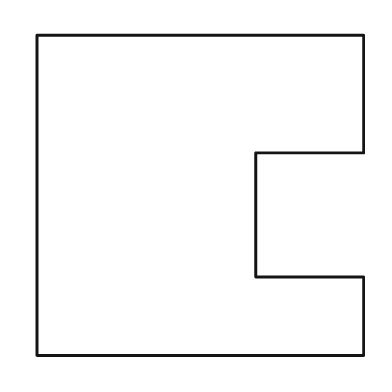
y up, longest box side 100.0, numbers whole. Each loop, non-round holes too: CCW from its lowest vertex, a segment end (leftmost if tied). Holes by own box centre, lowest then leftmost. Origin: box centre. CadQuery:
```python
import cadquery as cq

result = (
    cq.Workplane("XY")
    .moveTo(-50.0, -49.0)
    .lineTo(50.0, -49.0)
    .lineTo(50.0, -25.0)
    .lineTo(17.0, -25.0)
    .lineTo(17.0, 13.0)
    .lineTo(50.0, 13.0)
    .lineTo(50.0, 49.0)
    .lineTo(-50.0, 49.0)
    .close()
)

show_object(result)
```